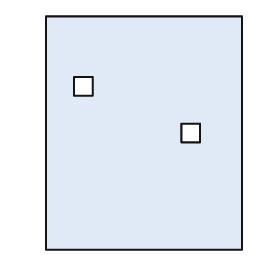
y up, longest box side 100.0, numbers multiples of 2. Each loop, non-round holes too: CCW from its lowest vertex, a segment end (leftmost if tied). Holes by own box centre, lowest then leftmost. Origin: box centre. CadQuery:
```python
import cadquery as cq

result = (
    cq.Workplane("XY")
    .moveTo(-42.0, -50.0)
    .lineTo(42.0, -50.0)
    .lineTo(42.0, 50.0)
    .lineTo(-42.0, 50.0)
    .close()
    .moveTo(16.0, -4.0)
    .lineTo(24.0, -4.0)
    .lineTo(24.0, 4.0)
    .lineTo(16.0, 4.0)
    .close()
    .moveTo(-30.0, 16.0)
    .lineTo(-22.0, 16.0)
    .lineTo(-22.0, 24.0)
    .lineTo(-30.0, 24.0)
    .close()
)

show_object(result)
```